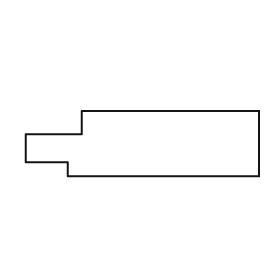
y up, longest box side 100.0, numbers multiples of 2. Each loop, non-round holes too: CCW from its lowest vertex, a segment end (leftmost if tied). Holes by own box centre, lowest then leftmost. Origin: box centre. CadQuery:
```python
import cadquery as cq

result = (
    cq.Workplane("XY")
    .moveTo(-32.0, -14.0)
    .lineTo(50.0, -14.0)
    .lineTo(50.0, 14.0)
    .lineTo(-26.0, 14.0)
    .lineTo(-26.0, 4.0)
    .lineTo(-50.0, 4.0)
    .lineTo(-50.0, -8.0)
    .lineTo(-32.0, -8.0)
    .close()
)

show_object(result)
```